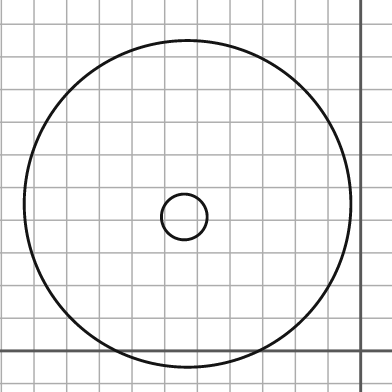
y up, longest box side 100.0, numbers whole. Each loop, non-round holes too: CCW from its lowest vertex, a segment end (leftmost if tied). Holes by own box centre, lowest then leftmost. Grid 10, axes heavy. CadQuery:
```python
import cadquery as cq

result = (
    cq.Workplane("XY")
    .moveTo(-53.0, 45.0)
    .circle(50.0)
    .moveTo(-54.0, 41.0)
    .circle(7.0)
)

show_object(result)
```